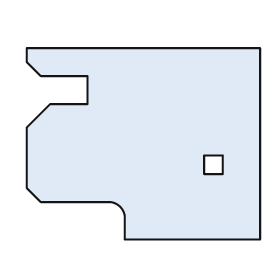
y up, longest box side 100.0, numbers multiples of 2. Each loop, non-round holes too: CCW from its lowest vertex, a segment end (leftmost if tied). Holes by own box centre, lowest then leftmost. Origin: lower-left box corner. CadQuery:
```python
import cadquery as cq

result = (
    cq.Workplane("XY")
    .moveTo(42.0, 0.0)
    .lineTo(100.0, 0.0)
    .lineTo(100.0, 82.0)
    .lineTo(0.0, 82.0)
    .lineTo(0.0, 76.0)
    .lineTo(6.0, 70.0)
    .lineTo(26.0, 70.0)
    .lineTo(26.0, 58.0)
    .lineTo(10.0, 58.0)
    .lineTo(0.0, 48.0)
    .lineTo(0.0, 22.0)
    .lineTo(6.0, 16.0)
    .lineTo(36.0, 16.0)
    .threePointArc((40.0, 14.0), (42.0, 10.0))
    .close()
    .moveTo(76.0, 28.0)
    .lineTo(84.0, 28.0)
    .lineTo(84.0, 36.0)
    .lineTo(76.0, 36.0)
    .close()
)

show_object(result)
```